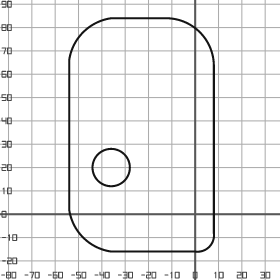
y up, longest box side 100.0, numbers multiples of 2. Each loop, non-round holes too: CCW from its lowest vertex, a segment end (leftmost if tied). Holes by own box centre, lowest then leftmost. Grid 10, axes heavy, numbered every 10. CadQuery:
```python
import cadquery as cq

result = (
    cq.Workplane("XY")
    .moveTo(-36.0, -16.0)
    .lineTo(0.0, -16.0)
    .threePointArc((6.0, -14.0), (8.0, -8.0))
    .lineTo(8.0, 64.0)
    .threePointArc((2.0, 78.0), (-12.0, 84.0))
    .lineTo(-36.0, 84.0)
    .threePointArc((-48.0, 78.0), (-54.0, 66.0))
    .lineTo(-54.0, 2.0)
    .threePointArc((-48.0, -10.0), (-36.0, -16.0))
    .close()
    .moveTo(-36.0, 20.0)
    .circle(8.0)
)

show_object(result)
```